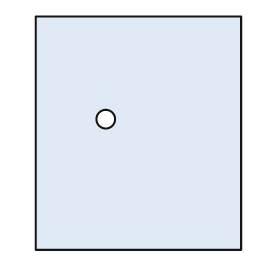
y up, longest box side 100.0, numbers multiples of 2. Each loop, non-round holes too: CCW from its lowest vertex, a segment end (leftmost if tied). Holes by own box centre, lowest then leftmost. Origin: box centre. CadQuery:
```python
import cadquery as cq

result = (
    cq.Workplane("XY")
    .moveTo(-44.0, -50.0)
    .lineTo(44.0, -50.0)
    .lineTo(44.0, 50.0)
    .lineTo(-44.0, 50.0)
    .close()
    .moveTo(-14.0, 6.0)
    .circle(4.0)
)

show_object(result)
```